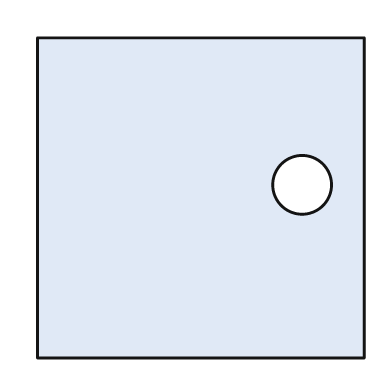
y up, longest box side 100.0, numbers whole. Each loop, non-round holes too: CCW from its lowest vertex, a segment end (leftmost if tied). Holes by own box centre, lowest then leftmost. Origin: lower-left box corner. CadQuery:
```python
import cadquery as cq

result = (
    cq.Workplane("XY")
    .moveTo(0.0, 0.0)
    .lineTo(100.0, 0.0)
    .lineTo(100.0, 98.0)
    .lineTo(0.0, 98.0)
    .close()
    .moveTo(81.0, 53.0)
    .circle(9.0)
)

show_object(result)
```